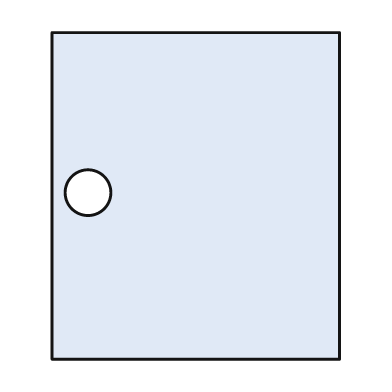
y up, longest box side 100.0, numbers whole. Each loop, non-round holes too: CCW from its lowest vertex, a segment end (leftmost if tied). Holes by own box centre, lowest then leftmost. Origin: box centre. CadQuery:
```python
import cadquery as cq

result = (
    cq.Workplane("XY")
    .moveTo(-44.0, -50.0)
    .lineTo(44.0, -50.0)
    .lineTo(44.0, 50.0)
    .lineTo(-44.0, 50.0)
    .close()
    .moveTo(-33.0, 1.0)
    .circle(7.0)
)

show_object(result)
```